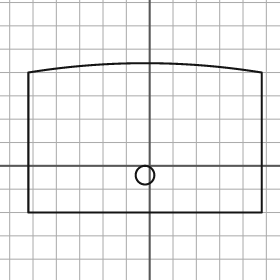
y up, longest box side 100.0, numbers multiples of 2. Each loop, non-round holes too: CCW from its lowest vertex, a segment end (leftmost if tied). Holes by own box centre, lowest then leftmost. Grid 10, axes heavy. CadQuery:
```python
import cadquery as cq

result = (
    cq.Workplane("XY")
    .moveTo(-52.0, -20.0)
    .lineTo(48.0, -20.0)
    .lineTo(48.0, 40.0)
    .threePointArc((-2.0, 44.0), (-52.0, 40.0))
    .close()
    .moveTo(-2.0, -4.0)
    .circle(4.0)
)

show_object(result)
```